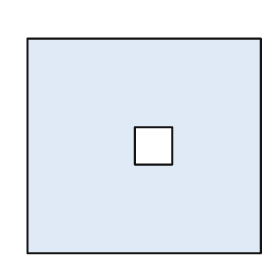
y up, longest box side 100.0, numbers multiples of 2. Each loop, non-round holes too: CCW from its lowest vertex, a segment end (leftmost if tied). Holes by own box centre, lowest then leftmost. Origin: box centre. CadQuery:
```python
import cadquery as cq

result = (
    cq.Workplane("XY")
    .moveTo(-50.0, -46.0)
    .lineTo(50.0, -46.0)
    .lineTo(50.0, 46.0)
    .lineTo(-50.0, 46.0)
    .close()
    .moveTo(-4.0, -8.0)
    .lineTo(12.0, -8.0)
    .lineTo(12.0, 8.0)
    .lineTo(-4.0, 8.0)
    .close()
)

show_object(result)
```